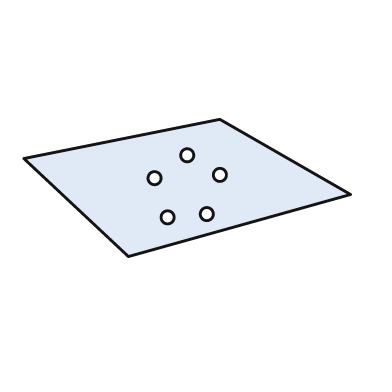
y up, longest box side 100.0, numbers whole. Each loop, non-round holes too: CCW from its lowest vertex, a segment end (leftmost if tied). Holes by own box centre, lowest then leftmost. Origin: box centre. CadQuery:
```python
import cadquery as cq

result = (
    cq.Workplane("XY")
    .moveTo(-18.0, -21.0)
    .lineTo(50.0, -2.0)
    .lineTo(10.0, 21.0)
    .lineTo(-50.0, 9.0)
    .close()
    .moveTo(-6.0, -9.0)
    .circle(2.0)
    .moveTo(6.0, -8.0)
    .circle(2.0)
    .moveTo(-10.0, 3.0)
    .circle(2.0)
    .moveTo(10.0, 4.0)
    .circle(2.0)
    .moveTo(0.0, 10.0)
    .circle(2.0)
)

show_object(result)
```